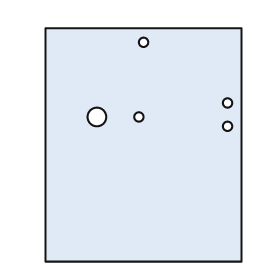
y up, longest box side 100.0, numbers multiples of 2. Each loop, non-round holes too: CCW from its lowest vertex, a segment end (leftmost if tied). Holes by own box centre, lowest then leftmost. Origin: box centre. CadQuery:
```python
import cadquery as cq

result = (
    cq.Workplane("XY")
    .moveTo(-42.0, -50.0)
    .lineTo(42.0, -50.0)
    .lineTo(42.0, 50.0)
    .lineTo(-42.0, 50.0)
    .close()
    .moveTo(36.0, 8.0)
    .circle(2.0)
    .moveTo(-20.0, 12.0)
    .circle(4.0)
    .moveTo(-2.0, 12.0)
    .circle(2.0)
    .moveTo(36.0, 18.0)
    .circle(2.0)
    .moveTo(0.0, 44.0)
    .circle(2.0)
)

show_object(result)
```